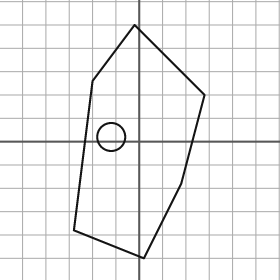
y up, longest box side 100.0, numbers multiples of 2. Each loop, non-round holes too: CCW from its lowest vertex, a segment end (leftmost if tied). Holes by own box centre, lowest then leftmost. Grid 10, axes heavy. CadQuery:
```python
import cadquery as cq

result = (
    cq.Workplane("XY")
    .moveTo(2.0, -50.0)
    .lineTo(18.0, -18.0)
    .lineTo(28.0, 20.0)
    .lineTo(-2.0, 50.0)
    .lineTo(-20.0, 26.0)
    .lineTo(-28.0, -38.0)
    .close()
    .moveTo(-12.0, 2.0)
    .circle(6.0)
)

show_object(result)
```